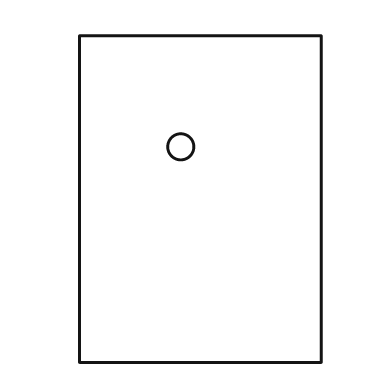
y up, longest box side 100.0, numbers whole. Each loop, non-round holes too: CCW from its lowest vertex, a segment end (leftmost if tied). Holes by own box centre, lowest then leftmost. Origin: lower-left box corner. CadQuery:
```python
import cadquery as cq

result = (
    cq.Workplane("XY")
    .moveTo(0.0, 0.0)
    .lineTo(74.0, 0.0)
    .lineTo(74.0, 100.0)
    .lineTo(0.0, 100.0)
    .close()
    .moveTo(31.0, 66.0)
    .circle(4.0)
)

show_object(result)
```